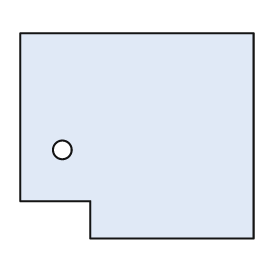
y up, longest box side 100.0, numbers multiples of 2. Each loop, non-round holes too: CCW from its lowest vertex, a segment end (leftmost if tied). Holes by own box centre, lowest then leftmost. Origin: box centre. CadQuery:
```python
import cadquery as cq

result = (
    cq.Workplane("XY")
    .moveTo(-20.0, -44.0)
    .lineTo(50.0, -44.0)
    .lineTo(50.0, 44.0)
    .lineTo(-50.0, 44.0)
    .lineTo(-50.0, -28.0)
    .lineTo(-20.0, -28.0)
    .close()
    .moveTo(-32.0, -6.0)
    .circle(4.0)
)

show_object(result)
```